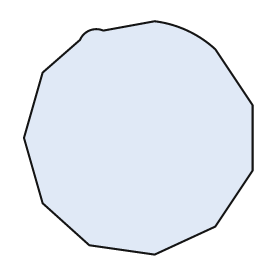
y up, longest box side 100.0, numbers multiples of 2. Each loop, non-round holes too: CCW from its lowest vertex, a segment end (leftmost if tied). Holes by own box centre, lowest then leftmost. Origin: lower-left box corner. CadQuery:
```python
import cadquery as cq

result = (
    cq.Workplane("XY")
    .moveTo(56.0, 0.0)
    .lineTo(82.0, 12.0)
    .lineTo(98.0, 36.0)
    .lineTo(98.0, 64.0)
    .lineTo(82.0, 88.0)
    .threePointArc((70.0, 96.0), (56.0, 100.0))
    .lineTo(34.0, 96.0)
    .threePointArc((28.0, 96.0), (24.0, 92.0))
    .lineTo(8.0, 78.0)
    .lineTo(0.0, 50.0)
    .lineTo(8.0, 22.0)
    .lineTo(28.0, 4.0)
    .close()
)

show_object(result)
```